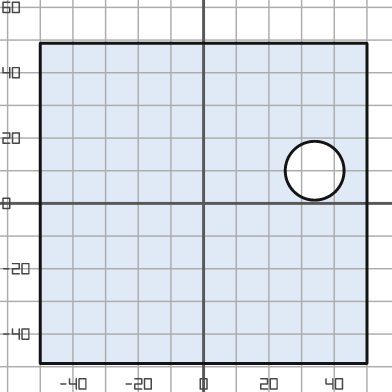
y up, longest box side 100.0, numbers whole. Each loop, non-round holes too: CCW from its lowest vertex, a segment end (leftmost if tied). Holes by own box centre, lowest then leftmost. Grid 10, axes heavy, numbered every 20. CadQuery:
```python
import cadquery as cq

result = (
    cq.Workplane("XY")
    .moveTo(-50.0, -49.0)
    .lineTo(50.0, -49.0)
    .lineTo(50.0, 49.0)
    .lineTo(-50.0, 49.0)
    .close()
    .moveTo(34.0, 10.0)
    .circle(9.0)
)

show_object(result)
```